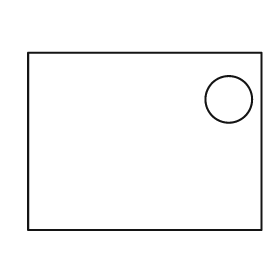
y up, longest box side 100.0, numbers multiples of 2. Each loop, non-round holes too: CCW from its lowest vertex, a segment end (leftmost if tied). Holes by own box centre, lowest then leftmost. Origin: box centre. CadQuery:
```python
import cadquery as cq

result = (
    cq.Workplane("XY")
    .moveTo(-50.0, -38.0)
    .lineTo(50.0, -38.0)
    .lineTo(50.0, 38.0)
    .lineTo(-50.0, 38.0)
    .close()
    .moveTo(36.0, 18.0)
    .circle(10.0)
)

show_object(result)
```